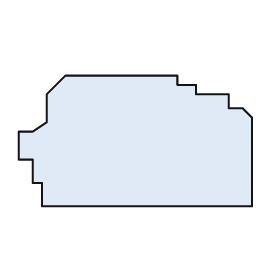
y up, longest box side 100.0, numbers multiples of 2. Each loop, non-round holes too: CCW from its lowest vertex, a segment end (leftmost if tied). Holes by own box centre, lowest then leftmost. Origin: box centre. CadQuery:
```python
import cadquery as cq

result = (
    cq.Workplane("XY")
    .moveTo(-40.0, -28.0)
    .lineTo(50.0, -28.0)
    .lineTo(50.0, 10.0)
    .lineTo(46.0, 14.0)
    .lineTo(40.0, 14.0)
    .lineTo(40.0, 20.0)
    .lineTo(26.0, 20.0)
    .lineTo(26.0, 24.0)
    .lineTo(18.0, 24.0)
    .lineTo(18.0, 28.0)
    .lineTo(-30.0, 28.0)
    .lineTo(-38.0, 20.0)
    .lineTo(-38.0, 8.0)
    .lineTo(-44.0, 4.0)
    .lineTo(-50.0, 4.0)
    .lineTo(-50.0, -8.0)
    .lineTo(-44.0, -8.0)
    .lineTo(-44.0, -18.0)
    .lineTo(-40.0, -18.0)
    .close()
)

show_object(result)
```